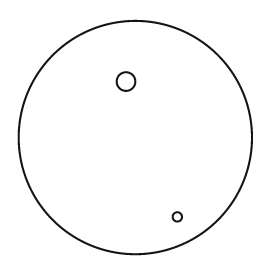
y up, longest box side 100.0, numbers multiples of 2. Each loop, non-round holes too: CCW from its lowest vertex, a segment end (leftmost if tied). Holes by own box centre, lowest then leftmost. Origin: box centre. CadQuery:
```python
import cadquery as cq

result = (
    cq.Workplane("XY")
    .moveTo(0.0, 0.0)
    .circle(50.0)
    .moveTo(18.0, -34.0)
    .circle(2.0)
    .moveTo(-4.0, 24.0)
    .circle(4.0)
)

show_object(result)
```